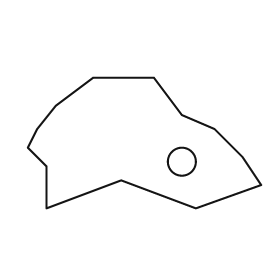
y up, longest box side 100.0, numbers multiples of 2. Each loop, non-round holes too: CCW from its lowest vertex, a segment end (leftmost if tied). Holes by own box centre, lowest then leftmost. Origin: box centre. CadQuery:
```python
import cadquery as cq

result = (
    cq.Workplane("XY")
    .moveTo(-42.0, -28.0)
    .lineTo(-10.0, -16.0)
    .lineTo(22.0, -28.0)
    .lineTo(50.0, -18.0)
    .lineTo(42.0, -6.0)
    .lineTo(30.0, 6.0)
    .lineTo(16.0, 12.0)
    .lineTo(4.0, 28.0)
    .lineTo(-22.0, 28.0)
    .lineTo(-38.0, 16.0)
    .lineTo(-46.0, 6.0)
    .lineTo(-50.0, -2.0)
    .lineTo(-42.0, -10.0)
    .close()
    .moveTo(16.0, -8.0)
    .circle(6.0)
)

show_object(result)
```